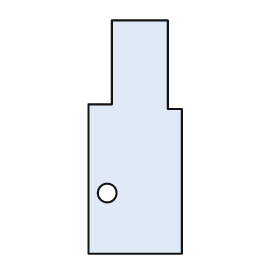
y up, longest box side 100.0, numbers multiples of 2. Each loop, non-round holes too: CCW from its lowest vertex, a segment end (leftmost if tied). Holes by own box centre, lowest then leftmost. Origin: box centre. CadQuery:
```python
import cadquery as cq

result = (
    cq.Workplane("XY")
    .moveTo(-20.0, -50.0)
    .lineTo(20.0, -50.0)
    .lineTo(20.0, 12.0)
    .lineTo(14.0, 12.0)
    .lineTo(14.0, 50.0)
    .lineTo(-10.0, 50.0)
    .lineTo(-10.0, 14.0)
    .lineTo(-20.0, 14.0)
    .close()
    .moveTo(-12.0, -24.0)
    .circle(4.0)
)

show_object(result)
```